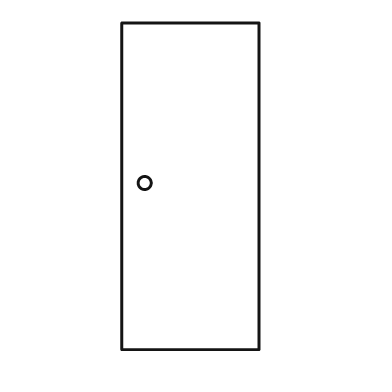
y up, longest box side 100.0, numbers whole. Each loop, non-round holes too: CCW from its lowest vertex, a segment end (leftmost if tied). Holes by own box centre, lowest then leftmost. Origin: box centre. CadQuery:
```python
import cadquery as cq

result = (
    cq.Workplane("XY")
    .moveTo(-21.0, -50.0)
    .lineTo(21.0, -50.0)
    .lineTo(21.0, 50.0)
    .lineTo(-21.0, 50.0)
    .close()
    .moveTo(-14.0, 1.0)
    .circle(2.0)
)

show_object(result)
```